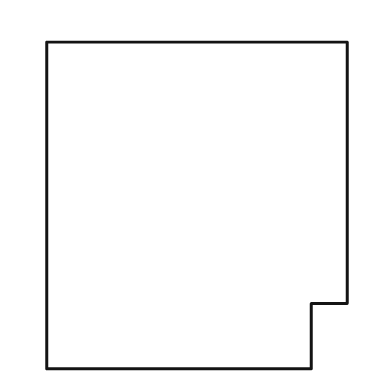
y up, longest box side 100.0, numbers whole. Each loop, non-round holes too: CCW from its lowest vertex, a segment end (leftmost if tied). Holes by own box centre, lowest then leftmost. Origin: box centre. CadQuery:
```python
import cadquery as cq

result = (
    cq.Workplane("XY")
    .moveTo(-46.0, -50.0)
    .lineTo(35.0, -50.0)
    .lineTo(35.0, -30.0)
    .lineTo(46.0, -30.0)
    .lineTo(46.0, 50.0)
    .lineTo(-46.0, 50.0)
    .close()
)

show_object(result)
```